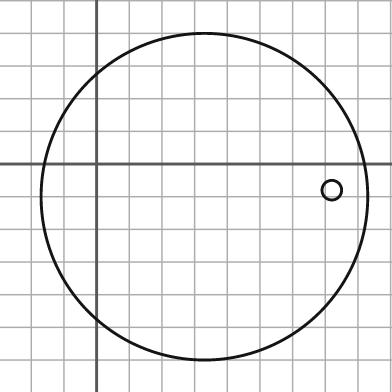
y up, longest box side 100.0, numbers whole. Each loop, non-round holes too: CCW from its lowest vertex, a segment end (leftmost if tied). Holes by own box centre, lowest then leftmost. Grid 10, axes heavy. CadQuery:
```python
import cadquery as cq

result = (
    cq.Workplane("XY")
    .moveTo(33.0, -10.0)
    .circle(50.0)
    .moveTo(72.0, -8.0)
    .circle(3.0)
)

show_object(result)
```